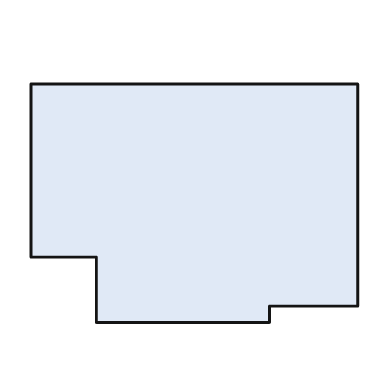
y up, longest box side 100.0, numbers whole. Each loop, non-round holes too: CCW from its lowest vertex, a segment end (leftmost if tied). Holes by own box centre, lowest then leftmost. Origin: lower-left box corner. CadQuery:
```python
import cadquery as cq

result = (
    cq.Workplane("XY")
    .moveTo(20.0, 0.0)
    .lineTo(73.0, 0.0)
    .lineTo(73.0, 5.0)
    .lineTo(100.0, 5.0)
    .lineTo(100.0, 73.0)
    .lineTo(0.0, 73.0)
    .lineTo(0.0, 20.0)
    .lineTo(20.0, 20.0)
    .close()
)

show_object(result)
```